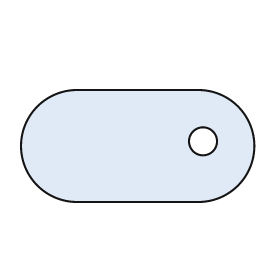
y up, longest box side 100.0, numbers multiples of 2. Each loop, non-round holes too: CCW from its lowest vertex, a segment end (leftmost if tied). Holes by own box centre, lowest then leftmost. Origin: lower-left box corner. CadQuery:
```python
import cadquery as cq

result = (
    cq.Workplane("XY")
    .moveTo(24.0, 0.0)
    .lineTo(76.0, 0.0)
    .threePointArc((100.0, 24.0), (76.0, 48.0))
    .lineTo(24.0, 48.0)
    .threePointArc((0.0, 24.0), (24.0, 0.0))
    .close()
    .moveTo(78.0, 26.0)
    .circle(6.0)
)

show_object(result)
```